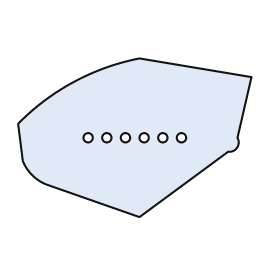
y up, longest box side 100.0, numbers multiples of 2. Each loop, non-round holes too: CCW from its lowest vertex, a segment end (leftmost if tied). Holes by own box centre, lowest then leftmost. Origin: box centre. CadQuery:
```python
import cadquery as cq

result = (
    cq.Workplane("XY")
    .moveTo(2.0, -34.0)
    .lineTo(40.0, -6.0)
    .threePointArc((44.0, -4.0), (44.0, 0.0))
    .lineTo(50.0, 26.0)
    .lineTo(2.0, 34.0)
    .threePointArc((-26.0, 24.0), (-50.0, 6.0))
    .lineTo(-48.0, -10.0)
    .threePointArc((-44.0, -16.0), (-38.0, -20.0))
    .close()
    .moveTo(-20.0, 0.0)
    .circle(2.0)
    .moveTo(-12.0, 0.0)
    .circle(2.0)
    .moveTo(-4.0, 0.0)
    .circle(2.0)
    .moveTo(4.0, 0.0)
    .circle(2.0)
    .moveTo(12.0, 0.0)
    .circle(2.0)
    .moveTo(20.0, 0.0)
    .circle(2.0)
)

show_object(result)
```